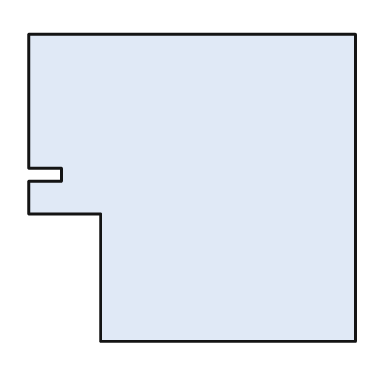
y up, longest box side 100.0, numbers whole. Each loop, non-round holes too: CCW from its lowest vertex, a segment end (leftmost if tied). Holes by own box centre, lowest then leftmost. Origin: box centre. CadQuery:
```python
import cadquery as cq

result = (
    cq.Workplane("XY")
    .moveTo(-28.0, -47.0)
    .lineTo(50.0, -47.0)
    .lineTo(50.0, 47.0)
    .lineTo(-50.0, 47.0)
    .lineTo(-50.0, 6.0)
    .lineTo(-40.0, 6.0)
    .lineTo(-40.0, 2.0)
    .lineTo(-50.0, 2.0)
    .lineTo(-50.0, -8.0)
    .lineTo(-28.0, -8.0)
    .close()
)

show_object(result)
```